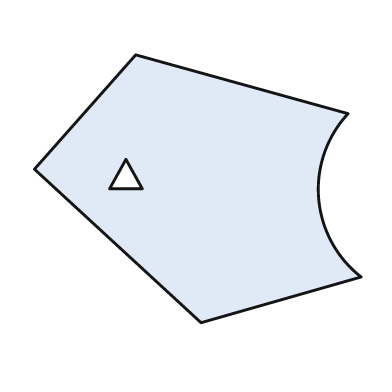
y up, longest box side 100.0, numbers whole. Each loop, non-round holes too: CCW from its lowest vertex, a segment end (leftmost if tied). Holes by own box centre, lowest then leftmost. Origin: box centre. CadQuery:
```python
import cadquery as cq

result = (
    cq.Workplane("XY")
    .moveTo(1.0, -41.0)
    .lineTo(50.0, -27.0)
    .threePointArc((37.0, -3.0), (46.0, 23.0))
    .lineTo(-19.0, 41.0)
    .lineTo(-50.0, 6.0)
    .close()
    .moveTo(-27.0, 0.0)
    .lineTo(-17.0, 0.0)
    .lineTo(-22.0, 9.0)
    .close()
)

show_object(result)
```